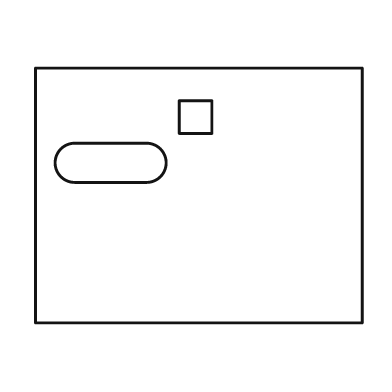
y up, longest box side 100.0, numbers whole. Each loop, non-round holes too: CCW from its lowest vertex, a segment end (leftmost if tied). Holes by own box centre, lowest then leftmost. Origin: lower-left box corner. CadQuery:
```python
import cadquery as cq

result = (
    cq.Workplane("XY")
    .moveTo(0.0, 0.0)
    .lineTo(100.0, 0.0)
    .lineTo(100.0, 78.0)
    .lineTo(0.0, 78.0)
    .close()
    .moveTo(12.0, 43.0)
    .lineTo(34.0, 43.0)
    .threePointArc((40.0, 49.0), (34.0, 55.0))
    .lineTo(12.0, 55.0)
    .threePointArc((6.0, 49.0), (12.0, 43.0))
    .close()
    .moveTo(44.0, 58.0)
    .lineTo(54.0, 58.0)
    .lineTo(54.0, 68.0)
    .lineTo(44.0, 68.0)
    .close()
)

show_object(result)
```